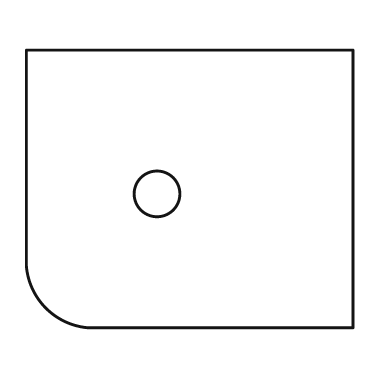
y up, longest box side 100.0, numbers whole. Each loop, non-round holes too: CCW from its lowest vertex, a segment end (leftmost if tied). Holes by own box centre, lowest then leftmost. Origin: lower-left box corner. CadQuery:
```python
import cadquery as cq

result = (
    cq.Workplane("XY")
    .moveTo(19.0, 0.0)
    .lineTo(100.0, 0.0)
    .lineTo(100.0, 85.0)
    .lineTo(0.0, 85.0)
    .lineTo(0.0, 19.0)
    .threePointArc((6.0, 6.0), (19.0, 0.0))
    .close()
    .moveTo(40.0, 41.0)
    .circle(7.0)
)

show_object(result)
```